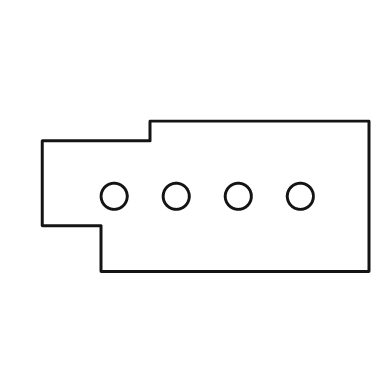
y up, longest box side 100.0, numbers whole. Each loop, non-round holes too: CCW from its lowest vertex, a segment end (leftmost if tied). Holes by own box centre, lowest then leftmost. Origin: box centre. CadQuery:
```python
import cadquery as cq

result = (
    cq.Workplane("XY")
    .moveTo(-32.0, -23.0)
    .lineTo(50.0, -23.0)
    .lineTo(50.0, 23.0)
    .lineTo(-17.0, 23.0)
    .lineTo(-17.0, 17.0)
    .lineTo(-50.0, 17.0)
    .lineTo(-50.0, -9.0)
    .lineTo(-32.0, -9.0)
    .close()
    .moveTo(-28.0, 0.0)
    .circle(4.0)
    .moveTo(-9.0, 0.0)
    .circle(4.0)
    .moveTo(10.0, 0.0)
    .circle(4.0)
    .moveTo(29.0, 0.0)
    .circle(4.0)
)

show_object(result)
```